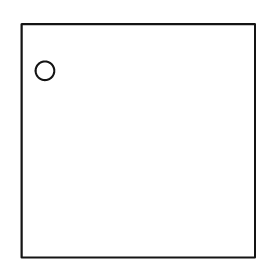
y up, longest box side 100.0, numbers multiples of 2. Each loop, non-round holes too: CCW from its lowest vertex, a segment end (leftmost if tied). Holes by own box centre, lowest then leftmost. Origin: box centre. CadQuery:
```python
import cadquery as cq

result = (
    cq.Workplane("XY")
    .moveTo(-50.0, -50.0)
    .lineTo(50.0, -50.0)
    .lineTo(50.0, 50.0)
    .lineTo(-50.0, 50.0)
    .close()
    .moveTo(-40.0, 30.0)
    .circle(4.0)
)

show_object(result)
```